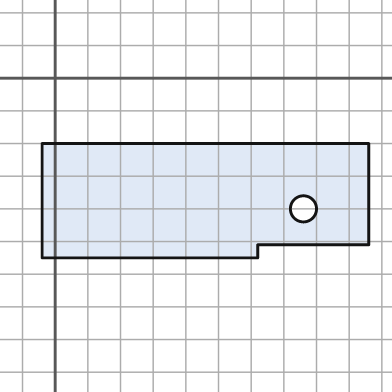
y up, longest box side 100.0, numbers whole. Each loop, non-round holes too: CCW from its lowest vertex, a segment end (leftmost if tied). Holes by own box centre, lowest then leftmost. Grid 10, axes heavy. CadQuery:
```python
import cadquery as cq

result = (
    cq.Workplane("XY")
    .moveTo(-4.0, -55.0)
    .lineTo(62.0, -55.0)
    .lineTo(62.0, -51.0)
    .lineTo(96.0, -51.0)
    .lineTo(96.0, -20.0)
    .lineTo(-4.0, -20.0)
    .close()
    .moveTo(76.0, -40.0)
    .circle(4.0)
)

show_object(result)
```